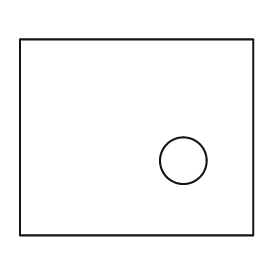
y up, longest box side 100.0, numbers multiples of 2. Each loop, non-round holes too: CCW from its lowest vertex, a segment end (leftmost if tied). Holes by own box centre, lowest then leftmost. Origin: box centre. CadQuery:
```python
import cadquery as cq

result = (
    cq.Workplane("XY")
    .moveTo(-50.0, -42.0)
    .lineTo(50.0, -42.0)
    .lineTo(50.0, 42.0)
    .lineTo(-50.0, 42.0)
    .close()
    .moveTo(20.0, -10.0)
    .circle(10.0)
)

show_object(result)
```